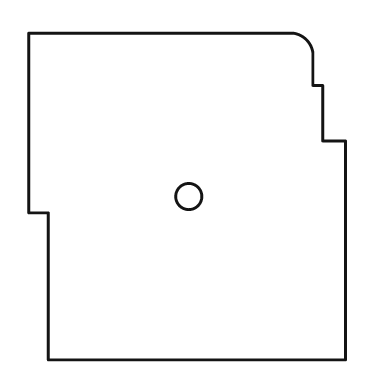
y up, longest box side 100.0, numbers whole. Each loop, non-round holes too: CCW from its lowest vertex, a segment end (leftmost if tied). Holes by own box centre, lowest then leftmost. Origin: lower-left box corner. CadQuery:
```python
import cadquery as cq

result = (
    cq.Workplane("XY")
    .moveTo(6.0, 0.0)
    .lineTo(97.0, 0.0)
    .lineTo(97.0, 67.0)
    .lineTo(90.0, 67.0)
    .lineTo(90.0, 84.0)
    .lineTo(87.0, 84.0)
    .lineTo(87.0, 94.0)
    .threePointArc((85.0, 98.0), (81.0, 100.0))
    .lineTo(0.0, 100.0)
    .lineTo(0.0, 45.0)
    .lineTo(6.0, 45.0)
    .close()
    .moveTo(49.0, 50.0)
    .circle(4.0)
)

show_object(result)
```